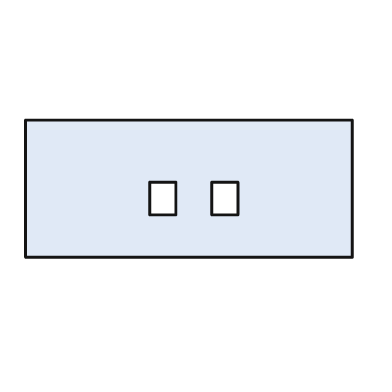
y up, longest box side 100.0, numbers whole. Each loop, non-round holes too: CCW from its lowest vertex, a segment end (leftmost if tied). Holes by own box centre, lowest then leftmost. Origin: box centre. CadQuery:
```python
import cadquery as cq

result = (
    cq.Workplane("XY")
    .moveTo(-50.0, -21.0)
    .lineTo(50.0, -21.0)
    .lineTo(50.0, 21.0)
    .lineTo(-50.0, 21.0)
    .close()
    .moveTo(-12.0, -8.0)
    .lineTo(-4.0, -8.0)
    .lineTo(-4.0, 2.0)
    .lineTo(-12.0, 2.0)
    .close()
    .moveTo(7.0, -8.0)
    .lineTo(15.0, -8.0)
    .lineTo(15.0, 2.0)
    .lineTo(7.0, 2.0)
    .close()
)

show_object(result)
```